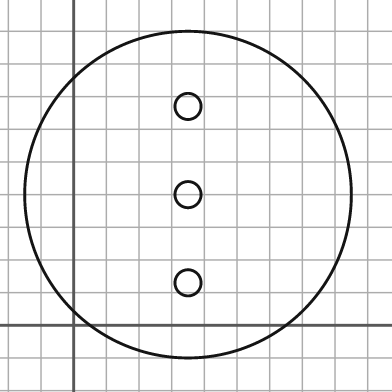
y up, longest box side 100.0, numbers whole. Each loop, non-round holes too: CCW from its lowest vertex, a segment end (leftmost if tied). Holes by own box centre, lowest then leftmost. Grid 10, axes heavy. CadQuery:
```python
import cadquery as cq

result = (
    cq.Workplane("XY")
    .moveTo(35.0, 40.0)
    .circle(50.0)
    .moveTo(35.0, 13.0)
    .circle(4.0)
    .moveTo(35.0, 40.0)
    .circle(4.0)
    .moveTo(35.0, 67.0)
    .circle(4.0)
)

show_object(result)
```